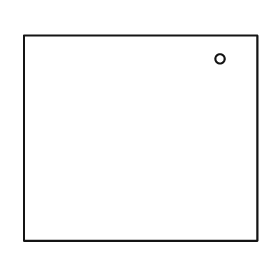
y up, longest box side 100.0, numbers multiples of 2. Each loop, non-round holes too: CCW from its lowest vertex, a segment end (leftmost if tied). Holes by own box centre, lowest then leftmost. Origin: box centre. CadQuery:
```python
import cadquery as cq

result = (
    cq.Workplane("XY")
    .moveTo(-50.0, -44.0)
    .lineTo(50.0, -44.0)
    .lineTo(50.0, 44.0)
    .lineTo(-50.0, 44.0)
    .close()
    .moveTo(34.0, 34.0)
    .circle(2.0)
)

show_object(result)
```